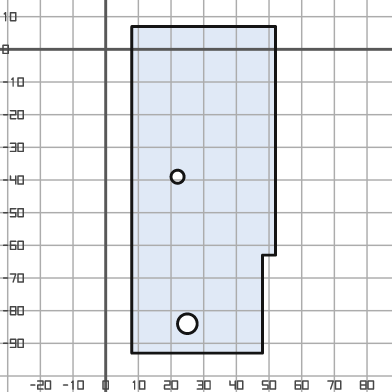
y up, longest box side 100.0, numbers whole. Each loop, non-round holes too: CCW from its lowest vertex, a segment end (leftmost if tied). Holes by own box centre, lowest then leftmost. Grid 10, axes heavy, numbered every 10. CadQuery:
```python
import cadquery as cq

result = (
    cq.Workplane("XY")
    .moveTo(8.0, -93.0)
    .lineTo(48.0, -93.0)
    .lineTo(48.0, -63.0)
    .lineTo(52.0, -63.0)
    .lineTo(52.0, 7.0)
    .lineTo(8.0, 7.0)
    .close()
    .moveTo(25.0, -84.0)
    .circle(3.0)
    .moveTo(22.0, -39.0)
    .circle(2.0)
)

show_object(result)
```